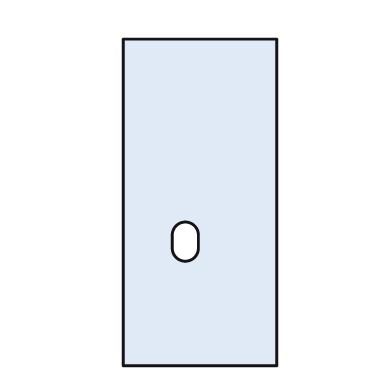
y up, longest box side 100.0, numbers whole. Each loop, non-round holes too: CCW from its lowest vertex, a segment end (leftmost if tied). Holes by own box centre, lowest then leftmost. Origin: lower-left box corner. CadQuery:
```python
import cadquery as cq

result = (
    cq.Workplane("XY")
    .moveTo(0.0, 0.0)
    .lineTo(47.0, 0.0)
    .lineTo(47.0, 100.0)
    .lineTo(0.0, 100.0)
    .close()
    .moveTo(15.0, 36.0)
    .threePointArc((19.0, 32.0), (23.0, 36.0))
    .lineTo(23.0, 40.0)
    .threePointArc((19.0, 44.0), (15.0, 40.0))
    .close()
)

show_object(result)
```